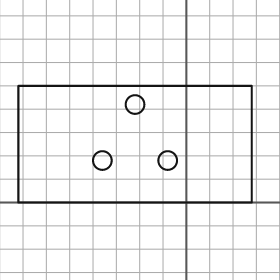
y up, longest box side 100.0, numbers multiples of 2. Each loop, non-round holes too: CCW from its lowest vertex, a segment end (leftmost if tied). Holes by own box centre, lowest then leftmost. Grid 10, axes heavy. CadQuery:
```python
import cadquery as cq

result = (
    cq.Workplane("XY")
    .moveTo(-72.0, 0.0)
    .lineTo(28.0, 0.0)
    .lineTo(28.0, 50.0)
    .lineTo(-72.0, 50.0)
    .close()
    .moveTo(-36.0, 18.0)
    .circle(4.0)
    .moveTo(-8.0, 18.0)
    .circle(4.0)
    .moveTo(-22.0, 42.0)
    .circle(4.0)
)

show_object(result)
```